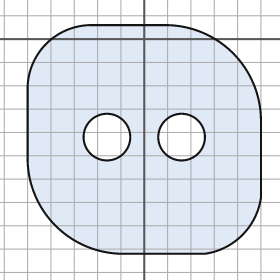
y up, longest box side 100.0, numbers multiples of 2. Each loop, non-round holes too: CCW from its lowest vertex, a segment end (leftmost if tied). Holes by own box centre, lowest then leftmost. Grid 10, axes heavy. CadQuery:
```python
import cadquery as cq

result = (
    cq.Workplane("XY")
    .moveTo(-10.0, -92.0)
    .lineTo(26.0, -92.0)
    .threePointArc((42.0, -84.0), (50.0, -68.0))
    .lineTo(50.0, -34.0)
    .threePointArc((38.0, -6.0), (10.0, 6.0))
    .lineTo(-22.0, 6.0)
    .threePointArc((-42.0, -2.0), (-50.0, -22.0))
    .lineTo(-50.0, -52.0)
    .threePointArc((-38.0, -80.0), (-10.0, -92.0))
    .close()
    .moveTo(-16.0, -42.0)
    .circle(10.0)
    .moveTo(16.0, -42.0)
    .circle(10.0)
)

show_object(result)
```